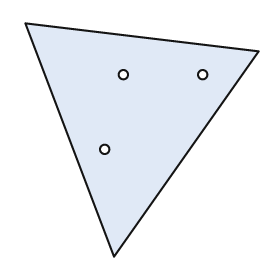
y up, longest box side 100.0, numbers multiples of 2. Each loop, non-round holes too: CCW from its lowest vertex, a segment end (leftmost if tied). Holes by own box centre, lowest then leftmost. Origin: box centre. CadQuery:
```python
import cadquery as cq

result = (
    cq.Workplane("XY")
    .moveTo(-12.0, -50.0)
    .lineTo(50.0, 38.0)
    .lineTo(-50.0, 50.0)
    .close()
    .moveTo(-16.0, -4.0)
    .circle(2.0)
    .moveTo(-8.0, 28.0)
    .circle(2.0)
    .moveTo(26.0, 28.0)
    .circle(2.0)
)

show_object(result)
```